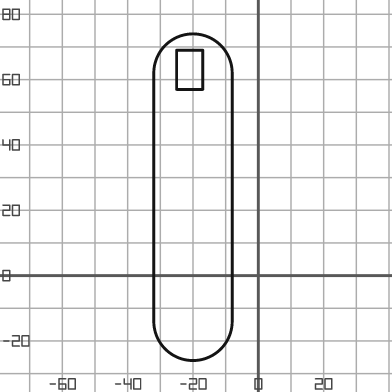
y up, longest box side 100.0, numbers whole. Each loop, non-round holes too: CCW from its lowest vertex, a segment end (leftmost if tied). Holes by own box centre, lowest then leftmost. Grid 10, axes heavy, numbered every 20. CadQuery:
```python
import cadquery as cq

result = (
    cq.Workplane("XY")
    .moveTo(-32.0, -14.0)
    .threePointArc((-20.0, -26.0), (-8.0, -14.0))
    .lineTo(-8.0, 62.0)
    .threePointArc((-20.0, 74.0), (-32.0, 62.0))
    .close()
    .moveTo(-25.0, 57.0)
    .lineTo(-17.0, 57.0)
    .lineTo(-17.0, 69.0)
    .lineTo(-25.0, 69.0)
    .close()
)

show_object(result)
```